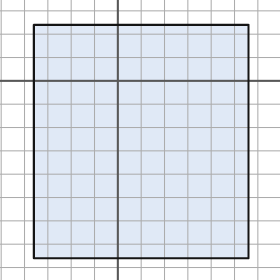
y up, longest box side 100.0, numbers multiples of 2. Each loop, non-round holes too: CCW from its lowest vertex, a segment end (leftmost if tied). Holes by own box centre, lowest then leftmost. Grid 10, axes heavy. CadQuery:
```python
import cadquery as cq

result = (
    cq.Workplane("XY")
    .moveTo(-36.0, -76.0)
    .lineTo(56.0, -76.0)
    .lineTo(56.0, 24.0)
    .lineTo(-36.0, 24.0)
    .close()
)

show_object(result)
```